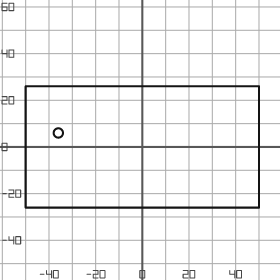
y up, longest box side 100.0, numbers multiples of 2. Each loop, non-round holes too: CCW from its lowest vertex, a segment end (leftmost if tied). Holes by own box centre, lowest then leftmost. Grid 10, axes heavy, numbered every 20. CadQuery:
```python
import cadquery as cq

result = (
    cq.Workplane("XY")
    .moveTo(-50.0, -26.0)
    .lineTo(50.0, -26.0)
    .lineTo(50.0, 26.0)
    .lineTo(-50.0, 26.0)
    .close()
    .moveTo(-36.0, 6.0)
    .circle(2.0)
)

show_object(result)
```